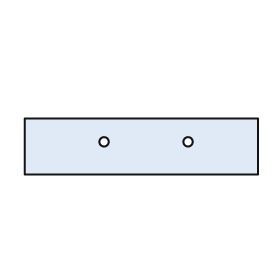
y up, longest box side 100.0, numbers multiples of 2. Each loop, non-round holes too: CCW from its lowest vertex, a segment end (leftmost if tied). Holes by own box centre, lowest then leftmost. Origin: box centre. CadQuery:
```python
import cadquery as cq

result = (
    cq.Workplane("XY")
    .moveTo(-50.0, -12.0)
    .lineTo(50.0, -12.0)
    .lineTo(50.0, 12.0)
    .lineTo(-50.0, 12.0)
    .close()
    .moveTo(-16.0, 2.0)
    .circle(2.0)
    .moveTo(20.0, 2.0)
    .circle(2.0)
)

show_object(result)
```